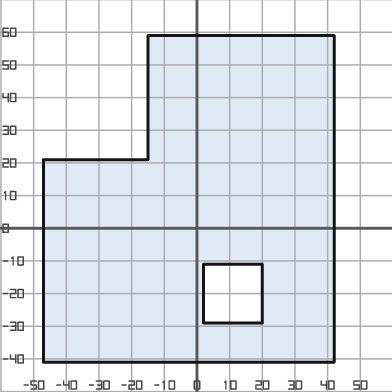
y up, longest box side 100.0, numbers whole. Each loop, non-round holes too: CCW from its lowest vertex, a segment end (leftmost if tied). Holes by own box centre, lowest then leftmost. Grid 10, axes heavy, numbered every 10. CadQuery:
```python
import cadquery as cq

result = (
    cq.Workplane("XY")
    .moveTo(-47.0, -41.0)
    .lineTo(42.0, -41.0)
    .lineTo(42.0, 59.0)
    .lineTo(-15.0, 59.0)
    .lineTo(-15.0, 21.0)
    .lineTo(-47.0, 21.0)
    .close()
    .moveTo(2.0, -29.0)
    .lineTo(20.0, -29.0)
    .lineTo(20.0, -11.0)
    .lineTo(2.0, -11.0)
    .close()
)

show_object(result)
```